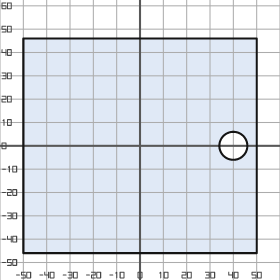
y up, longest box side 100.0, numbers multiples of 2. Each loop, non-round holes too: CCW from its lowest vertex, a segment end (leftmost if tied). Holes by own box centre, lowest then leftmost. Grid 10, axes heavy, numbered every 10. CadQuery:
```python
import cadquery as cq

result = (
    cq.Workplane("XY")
    .moveTo(-50.0, -46.0)
    .lineTo(50.0, -46.0)
    .lineTo(50.0, 46.0)
    .lineTo(-50.0, 46.0)
    .close()
    .moveTo(40.0, 0.0)
    .circle(6.0)
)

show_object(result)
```